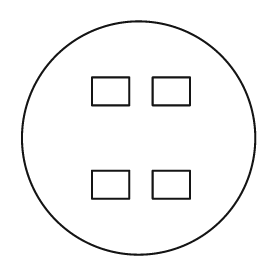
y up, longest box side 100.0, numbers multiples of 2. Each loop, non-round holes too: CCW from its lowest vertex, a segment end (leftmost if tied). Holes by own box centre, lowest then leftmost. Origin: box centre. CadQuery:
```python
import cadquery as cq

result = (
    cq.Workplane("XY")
    .moveTo(0.0, 0.0)
    .circle(50.0)
    .moveTo(-20.0, -26.0)
    .lineTo(-4.0, -26.0)
    .lineTo(-4.0, -14.0)
    .lineTo(-20.0, -14.0)
    .close()
    .moveTo(6.0, -26.0)
    .lineTo(22.0, -26.0)
    .lineTo(22.0, -14.0)
    .lineTo(6.0, -14.0)
    .close()
    .moveTo(-20.0, 14.0)
    .lineTo(-4.0, 14.0)
    .lineTo(-4.0, 26.0)
    .lineTo(-20.0, 26.0)
    .close()
    .moveTo(6.0, 14.0)
    .lineTo(22.0, 14.0)
    .lineTo(22.0, 26.0)
    .lineTo(6.0, 26.0)
    .close()
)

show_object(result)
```